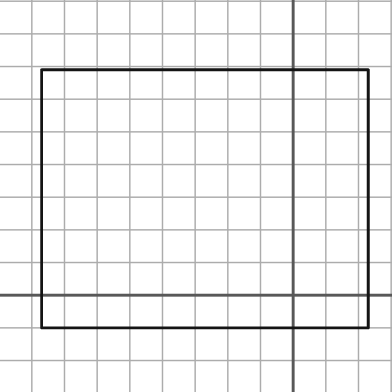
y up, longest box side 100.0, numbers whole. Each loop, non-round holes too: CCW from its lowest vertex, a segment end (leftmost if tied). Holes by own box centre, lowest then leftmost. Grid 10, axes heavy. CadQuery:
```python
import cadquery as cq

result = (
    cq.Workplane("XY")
    .moveTo(-77.0, -10.0)
    .lineTo(23.0, -10.0)
    .lineTo(23.0, 69.0)
    .lineTo(-77.0, 69.0)
    .close()
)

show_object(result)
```